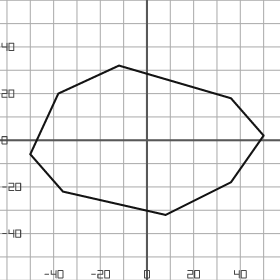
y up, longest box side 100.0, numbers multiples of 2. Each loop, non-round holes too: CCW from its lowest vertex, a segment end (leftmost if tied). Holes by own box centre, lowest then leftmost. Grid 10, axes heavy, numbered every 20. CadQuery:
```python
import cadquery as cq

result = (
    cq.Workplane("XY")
    .moveTo(8.0, -32.0)
    .lineTo(36.0, -18.0)
    .lineTo(50.0, 2.0)
    .lineTo(36.0, 18.0)
    .lineTo(-12.0, 32.0)
    .lineTo(-38.0, 20.0)
    .lineTo(-50.0, -6.0)
    .lineTo(-36.0, -22.0)
    .close()
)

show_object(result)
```